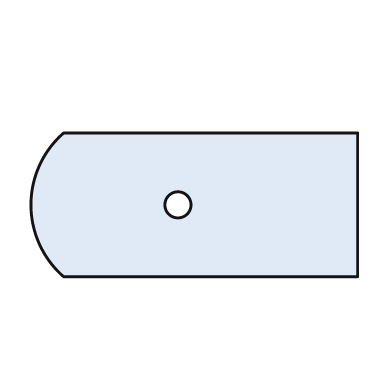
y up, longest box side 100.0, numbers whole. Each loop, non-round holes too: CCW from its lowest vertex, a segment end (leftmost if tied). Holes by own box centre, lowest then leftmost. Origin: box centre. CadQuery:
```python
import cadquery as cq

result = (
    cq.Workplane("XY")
    .moveTo(-40.0, -22.0)
    .lineTo(50.0, -22.0)
    .lineTo(50.0, 22.0)
    .lineTo(-40.0, 22.0)
    .threePointArc((-50.0, 0.0), (-40.0, -22.0))
    .close()
    .moveTo(-5.0, 0.0)
    .circle(4.0)
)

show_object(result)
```